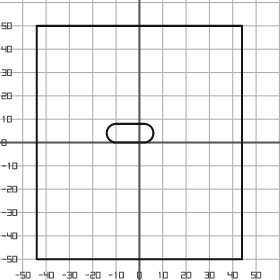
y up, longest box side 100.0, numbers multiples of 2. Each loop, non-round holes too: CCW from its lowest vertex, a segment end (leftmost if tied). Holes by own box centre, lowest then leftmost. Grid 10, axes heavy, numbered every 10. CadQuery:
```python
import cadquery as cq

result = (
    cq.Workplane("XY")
    .moveTo(-44.0, -50.0)
    .lineTo(44.0, -50.0)
    .lineTo(44.0, 50.0)
    .lineTo(-44.0, 50.0)
    .close()
    .moveTo(-10.0, 0.0)
    .lineTo(2.0, 0.0)
    .threePointArc((6.0, 4.0), (2.0, 8.0))
    .lineTo(-10.0, 8.0)
    .threePointArc((-14.0, 4.0), (-10.0, 0.0))
    .close()
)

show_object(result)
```